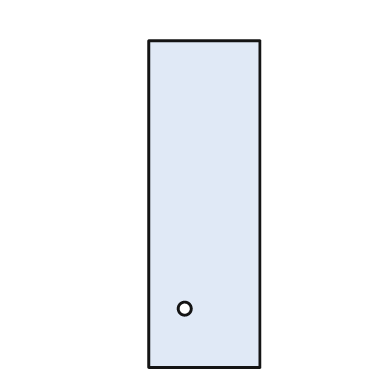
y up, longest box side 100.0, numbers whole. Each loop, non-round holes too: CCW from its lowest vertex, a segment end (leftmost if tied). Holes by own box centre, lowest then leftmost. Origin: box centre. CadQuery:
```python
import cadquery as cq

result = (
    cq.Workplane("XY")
    .moveTo(-17.0, -50.0)
    .lineTo(17.0, -50.0)
    .lineTo(17.0, 50.0)
    .lineTo(-17.0, 50.0)
    .close()
    .moveTo(-6.0, -32.0)
    .circle(2.0)
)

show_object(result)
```